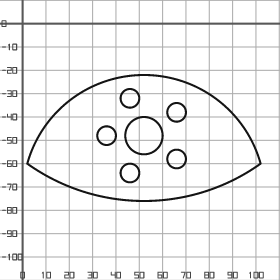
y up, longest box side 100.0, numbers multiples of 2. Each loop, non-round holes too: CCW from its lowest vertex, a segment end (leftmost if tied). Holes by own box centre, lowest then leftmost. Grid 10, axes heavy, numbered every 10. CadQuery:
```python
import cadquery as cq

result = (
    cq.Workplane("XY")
    .moveTo(2.0, -60.0)
    .threePointArc((52.0, -76.0), (102.0, -60.0))
    .threePointArc((52.0, -22.0), (2.0, -60.0))
    .close()
    .moveTo(46.0, -64.0)
    .circle(4.0)
    .moveTo(66.0, -58.0)
    .circle(4.0)
    .moveTo(36.0, -48.0)
    .circle(4.0)
    .moveTo(52.0, -48.0)
    .circle(8.0)
    .moveTo(66.0, -38.0)
    .circle(4.0)
    .moveTo(46.0, -32.0)
    .circle(4.0)
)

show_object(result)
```